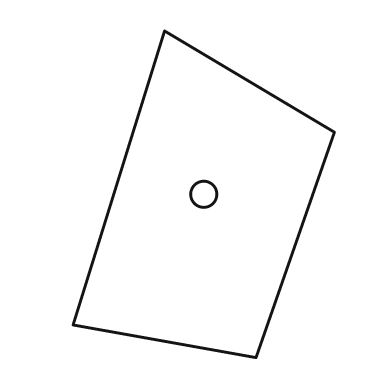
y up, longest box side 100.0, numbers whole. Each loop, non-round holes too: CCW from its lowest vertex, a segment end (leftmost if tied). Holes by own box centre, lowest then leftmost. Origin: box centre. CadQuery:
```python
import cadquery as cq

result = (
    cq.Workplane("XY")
    .moveTo(16.0, -50.0)
    .lineTo(40.0, 19.0)
    .lineTo(-12.0, 50.0)
    .lineTo(-40.0, -40.0)
    .close()
    .moveTo(0.0, 0.0)
    .circle(4.0)
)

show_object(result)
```